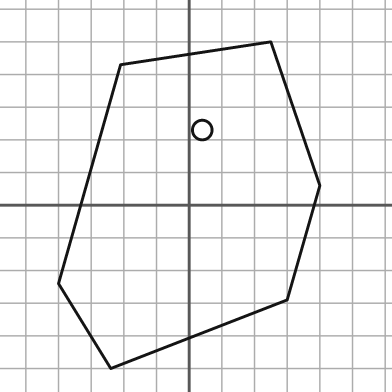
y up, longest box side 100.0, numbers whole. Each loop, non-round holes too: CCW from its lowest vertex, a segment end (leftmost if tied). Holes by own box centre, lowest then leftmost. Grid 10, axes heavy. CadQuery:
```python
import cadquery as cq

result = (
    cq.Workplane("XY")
    .moveTo(-24.0, -50.0)
    .lineTo(30.0, -29.0)
    .lineTo(40.0, 6.0)
    .lineTo(25.0, 50.0)
    .lineTo(-21.0, 43.0)
    .lineTo(-40.0, -24.0)
    .close()
    .moveTo(4.0, 23.0)
    .circle(3.0)
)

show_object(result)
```